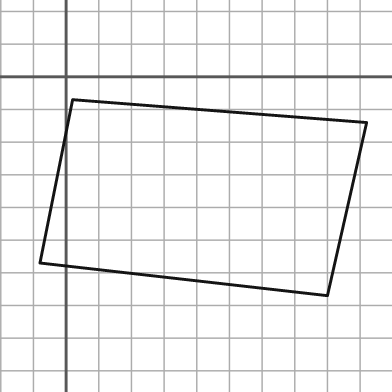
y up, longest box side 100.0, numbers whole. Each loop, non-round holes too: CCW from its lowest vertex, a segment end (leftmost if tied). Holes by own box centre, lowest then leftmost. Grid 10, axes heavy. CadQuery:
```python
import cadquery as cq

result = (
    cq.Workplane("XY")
    .moveTo(80.0, -67.0)
    .lineTo(92.0, -14.0)
    .lineTo(2.0, -7.0)
    .lineTo(-8.0, -57.0)
    .close()
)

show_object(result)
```